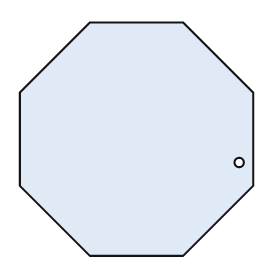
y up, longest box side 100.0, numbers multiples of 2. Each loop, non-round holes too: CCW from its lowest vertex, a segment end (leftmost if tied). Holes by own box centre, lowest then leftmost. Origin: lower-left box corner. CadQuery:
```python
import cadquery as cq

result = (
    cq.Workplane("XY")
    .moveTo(30.0, 0.0)
    .lineTo(70.0, 0.0)
    .lineTo(100.0, 30.0)
    .lineTo(100.0, 70.0)
    .lineTo(70.0, 100.0)
    .lineTo(30.0, 100.0)
    .lineTo(0.0, 70.0)
    .lineTo(0.0, 30.0)
    .close()
    .moveTo(94.0, 40.0)
    .circle(2.0)
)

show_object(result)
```